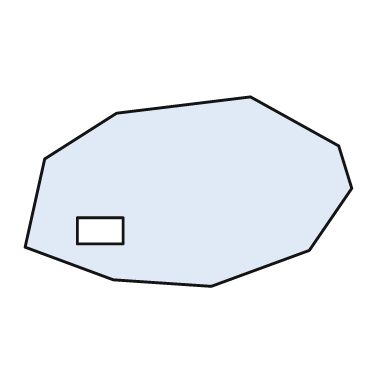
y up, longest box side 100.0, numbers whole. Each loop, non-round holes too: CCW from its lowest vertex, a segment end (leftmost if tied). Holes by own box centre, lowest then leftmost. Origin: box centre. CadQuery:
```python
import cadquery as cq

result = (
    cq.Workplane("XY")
    .moveTo(7.0, -29.0)
    .lineTo(37.0, -18.0)
    .lineTo(50.0, 1.0)
    .lineTo(46.0, 14.0)
    .lineTo(19.0, 29.0)
    .lineTo(-22.0, 24.0)
    .lineTo(-44.0, 10.0)
    .lineTo(-50.0, -17.0)
    .lineTo(-23.0, -27.0)
    .close()
    .moveTo(-34.0, -16.0)
    .lineTo(-20.0, -16.0)
    .lineTo(-20.0, -8.0)
    .lineTo(-34.0, -8.0)
    .close()
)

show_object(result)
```